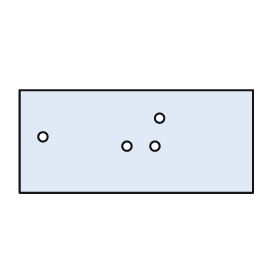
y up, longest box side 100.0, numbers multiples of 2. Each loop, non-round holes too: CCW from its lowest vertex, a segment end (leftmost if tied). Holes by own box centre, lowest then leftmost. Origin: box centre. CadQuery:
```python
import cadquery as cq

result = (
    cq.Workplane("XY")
    .moveTo(-50.0, -22.0)
    .lineTo(50.0, -22.0)
    .lineTo(50.0, 22.0)
    .lineTo(-50.0, 22.0)
    .close()
    .moveTo(-4.0, -2.0)
    .circle(2.0)
    .moveTo(8.0, -2.0)
    .circle(2.0)
    .moveTo(-40.0, 2.0)
    .circle(2.0)
    .moveTo(10.0, 10.0)
    .circle(2.0)
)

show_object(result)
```